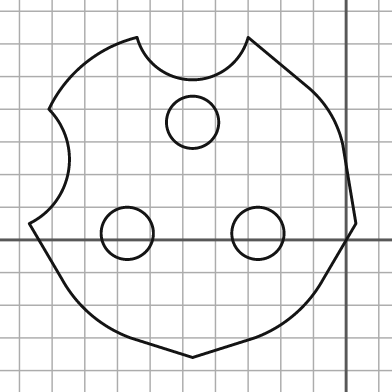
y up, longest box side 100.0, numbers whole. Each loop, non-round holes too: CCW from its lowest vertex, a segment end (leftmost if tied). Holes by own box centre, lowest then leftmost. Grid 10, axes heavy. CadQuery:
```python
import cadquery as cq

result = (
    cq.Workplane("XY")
    .moveTo(-47.0, -36.0)
    .lineTo(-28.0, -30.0)
    .threePointArc((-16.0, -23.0), (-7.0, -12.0))
    .lineTo(3.0, 5.0)
    .lineTo(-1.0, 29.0)
    .threePointArc((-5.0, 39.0), (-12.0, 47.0))
    .lineTo(-30.0, 62.0)
    .threePointArc((-47.0, 49.0), (-64.0, 62.0))
    .threePointArc((-80.0, 54.0), (-91.0, 40.0))
    .threePointArc((-85.0, 21.0), (-97.0, 5.0))
    .lineTo(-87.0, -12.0)
    .threePointArc((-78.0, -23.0), (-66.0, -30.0))
    .close()
    .moveTo(-67.0, 2.0)
    .circle(8.0)
    .moveTo(-27.0, 2.0)
    .circle(8.0)
    .moveTo(-47.0, 36.0)
    .circle(8.0)
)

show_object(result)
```